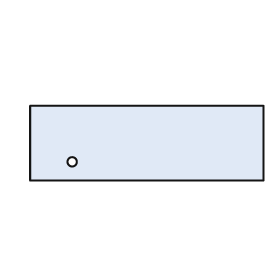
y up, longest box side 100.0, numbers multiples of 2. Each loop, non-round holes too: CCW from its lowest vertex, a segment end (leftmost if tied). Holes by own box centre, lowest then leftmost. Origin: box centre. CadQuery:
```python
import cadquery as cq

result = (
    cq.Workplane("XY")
    .moveTo(-50.0, -16.0)
    .lineTo(50.0, -16.0)
    .lineTo(50.0, 16.0)
    .lineTo(-50.0, 16.0)
    .close()
    .moveTo(-32.0, -8.0)
    .circle(2.0)
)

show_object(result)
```